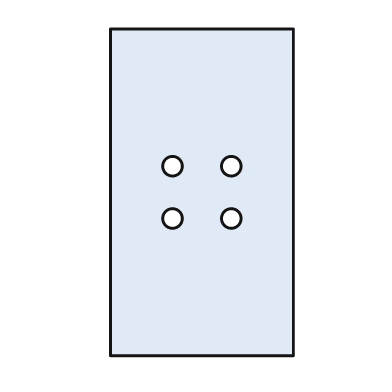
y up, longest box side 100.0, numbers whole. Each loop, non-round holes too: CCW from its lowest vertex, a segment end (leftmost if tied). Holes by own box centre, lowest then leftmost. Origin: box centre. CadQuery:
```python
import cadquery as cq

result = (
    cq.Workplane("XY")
    .moveTo(-28.0, -50.0)
    .lineTo(28.0, -50.0)
    .lineTo(28.0, 50.0)
    .lineTo(-28.0, 50.0)
    .close()
    .moveTo(-9.0, -8.0)
    .circle(3.0)
    .moveTo(9.0, -8.0)
    .circle(3.0)
    .moveTo(-9.0, 8.0)
    .circle(3.0)
    .moveTo(9.0, 8.0)
    .circle(3.0)
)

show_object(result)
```